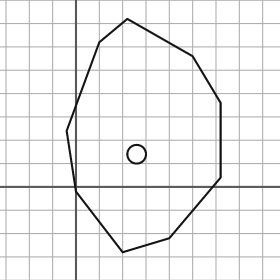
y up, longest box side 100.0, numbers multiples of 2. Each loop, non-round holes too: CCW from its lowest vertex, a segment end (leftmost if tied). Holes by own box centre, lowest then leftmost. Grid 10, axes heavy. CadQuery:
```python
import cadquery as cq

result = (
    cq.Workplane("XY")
    .moveTo(20.0, -28.0)
    .lineTo(40.0, -22.0)
    .lineTo(62.0, 4.0)
    .lineTo(62.0, 36.0)
    .lineTo(50.0, 56.0)
    .lineTo(22.0, 72.0)
    .lineTo(10.0, 62.0)
    .lineTo(-4.0, 24.0)
    .lineTo(0.0, -2.0)
    .close()
    .moveTo(26.0, 14.0)
    .circle(4.0)
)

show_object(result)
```